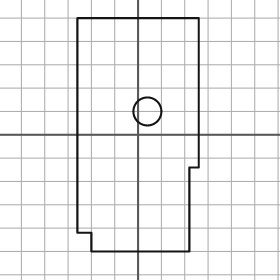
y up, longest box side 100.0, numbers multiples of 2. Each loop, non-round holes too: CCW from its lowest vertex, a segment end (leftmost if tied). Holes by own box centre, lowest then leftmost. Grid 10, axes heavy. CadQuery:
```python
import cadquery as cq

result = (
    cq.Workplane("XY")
    .moveTo(-20.0, -50.0)
    .lineTo(22.0, -50.0)
    .lineTo(22.0, -14.0)
    .lineTo(26.0, -14.0)
    .lineTo(26.0, 50.0)
    .lineTo(-26.0, 50.0)
    .lineTo(-26.0, -42.0)
    .lineTo(-20.0, -42.0)
    .close()
    .moveTo(4.0, 10.0)
    .circle(6.0)
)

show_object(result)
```